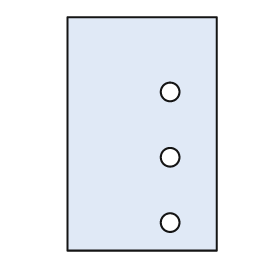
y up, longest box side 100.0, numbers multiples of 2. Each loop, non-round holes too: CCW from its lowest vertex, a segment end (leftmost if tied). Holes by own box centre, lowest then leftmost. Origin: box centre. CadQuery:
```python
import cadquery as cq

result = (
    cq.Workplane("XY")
    .moveTo(-32.0, -50.0)
    .lineTo(32.0, -50.0)
    .lineTo(32.0, 50.0)
    .lineTo(-32.0, 50.0)
    .close()
    .moveTo(12.0, -38.0)
    .circle(4.0)
    .moveTo(12.0, -10.0)
    .circle(4.0)
    .moveTo(12.0, 18.0)
    .circle(4.0)
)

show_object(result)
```